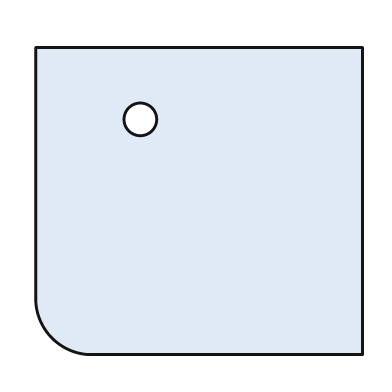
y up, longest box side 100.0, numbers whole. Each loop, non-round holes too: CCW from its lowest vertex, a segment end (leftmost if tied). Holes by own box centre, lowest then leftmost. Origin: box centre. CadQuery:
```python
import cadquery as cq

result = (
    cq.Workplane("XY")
    .moveTo(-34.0, -47.0)
    .lineTo(50.0, -47.0)
    .lineTo(50.0, 47.0)
    .lineTo(-50.0, 47.0)
    .lineTo(-50.0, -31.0)
    .threePointArc((-45.0, -42.0), (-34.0, -47.0))
    .close()
    .moveTo(-18.0, 25.0)
    .circle(5.0)
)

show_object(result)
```